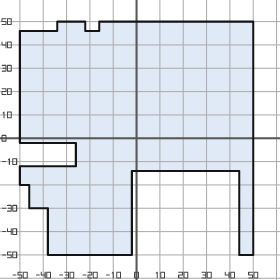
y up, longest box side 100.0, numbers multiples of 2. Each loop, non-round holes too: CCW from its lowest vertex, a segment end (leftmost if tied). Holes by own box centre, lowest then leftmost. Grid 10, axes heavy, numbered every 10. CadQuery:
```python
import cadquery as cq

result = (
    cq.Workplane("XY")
    .moveTo(-38.0, -50.0)
    .lineTo(-2.0, -50.0)
    .lineTo(-2.0, -14.0)
    .lineTo(44.0, -14.0)
    .lineTo(44.0, -50.0)
    .lineTo(50.0, -50.0)
    .lineTo(50.0, 50.0)
    .lineTo(-16.0, 50.0)
    .lineTo(-16.0, 46.0)
    .lineTo(-22.0, 46.0)
    .lineTo(-22.0, 50.0)
    .lineTo(-34.0, 50.0)
    .lineTo(-34.0, 46.0)
    .lineTo(-50.0, 46.0)
    .lineTo(-50.0, -2.0)
    .lineTo(-26.0, -2.0)
    .lineTo(-26.0, -12.0)
    .lineTo(-50.0, -12.0)
    .lineTo(-50.0, -20.0)
    .lineTo(-46.0, -20.0)
    .lineTo(-46.0, -30.0)
    .lineTo(-38.0, -30.0)
    .close()
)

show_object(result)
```